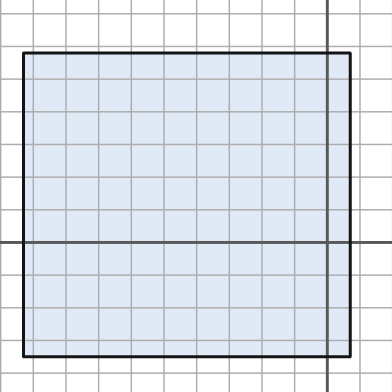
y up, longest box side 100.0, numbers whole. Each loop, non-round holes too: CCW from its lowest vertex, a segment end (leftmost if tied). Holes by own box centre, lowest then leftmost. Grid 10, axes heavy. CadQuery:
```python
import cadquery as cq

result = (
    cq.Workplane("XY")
    .moveTo(-93.0, -35.0)
    .lineTo(7.0, -35.0)
    .lineTo(7.0, 58.0)
    .lineTo(-93.0, 58.0)
    .close()
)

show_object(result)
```